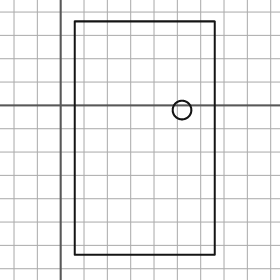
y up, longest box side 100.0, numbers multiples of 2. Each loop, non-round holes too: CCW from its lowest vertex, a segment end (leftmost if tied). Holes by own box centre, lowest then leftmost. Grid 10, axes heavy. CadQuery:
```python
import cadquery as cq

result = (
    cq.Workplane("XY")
    .moveTo(6.0, -64.0)
    .lineTo(66.0, -64.0)
    .lineTo(66.0, 36.0)
    .lineTo(6.0, 36.0)
    .close()
    .moveTo(52.0, -2.0)
    .circle(4.0)
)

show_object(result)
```